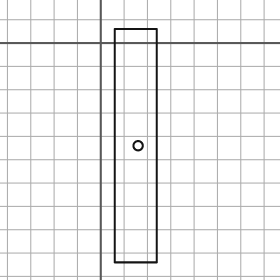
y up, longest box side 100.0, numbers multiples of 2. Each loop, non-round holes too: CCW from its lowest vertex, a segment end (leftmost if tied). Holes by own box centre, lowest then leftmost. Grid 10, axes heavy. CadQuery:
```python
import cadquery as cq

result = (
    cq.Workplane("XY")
    .moveTo(6.0, -94.0)
    .lineTo(24.0, -94.0)
    .lineTo(24.0, 6.0)
    .lineTo(6.0, 6.0)
    .close()
    .moveTo(16.0, -44.0)
    .circle(2.0)
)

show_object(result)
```